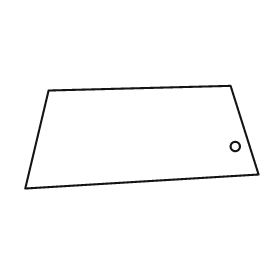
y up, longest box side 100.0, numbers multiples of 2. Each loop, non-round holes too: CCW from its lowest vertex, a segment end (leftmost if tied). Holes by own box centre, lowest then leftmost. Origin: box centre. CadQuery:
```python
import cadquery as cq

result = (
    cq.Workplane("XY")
    .moveTo(-50.0, -22.0)
    .lineTo(50.0, -16.0)
    .lineTo(38.0, 22.0)
    .lineTo(-40.0, 20.0)
    .close()
    .moveTo(40.0, -4.0)
    .circle(2.0)
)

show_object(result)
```